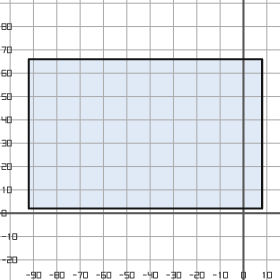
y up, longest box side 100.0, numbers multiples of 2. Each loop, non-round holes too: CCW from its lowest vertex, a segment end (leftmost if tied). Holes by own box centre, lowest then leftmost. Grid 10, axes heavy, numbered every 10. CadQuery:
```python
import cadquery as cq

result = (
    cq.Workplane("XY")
    .moveTo(-92.0, 2.0)
    .lineTo(8.0, 2.0)
    .lineTo(8.0, 66.0)
    .lineTo(-92.0, 66.0)
    .close()
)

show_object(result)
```